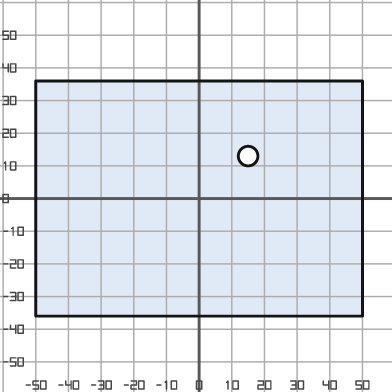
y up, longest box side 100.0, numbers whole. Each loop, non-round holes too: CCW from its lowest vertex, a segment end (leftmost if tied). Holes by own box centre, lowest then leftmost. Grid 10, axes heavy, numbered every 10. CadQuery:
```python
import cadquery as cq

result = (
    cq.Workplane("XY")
    .moveTo(-50.0, -36.0)
    .lineTo(50.0, -36.0)
    .lineTo(50.0, 36.0)
    .lineTo(-50.0, 36.0)
    .close()
    .moveTo(15.0, 13.0)
    .circle(3.0)
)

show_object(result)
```